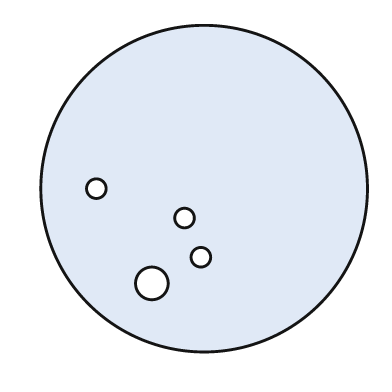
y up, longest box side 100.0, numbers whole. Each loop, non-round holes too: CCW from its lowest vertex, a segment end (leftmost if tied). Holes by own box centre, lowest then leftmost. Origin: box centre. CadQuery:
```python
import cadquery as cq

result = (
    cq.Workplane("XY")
    .moveTo(0.0, 0.0)
    .circle(50.0)
    .moveTo(-16.0, -29.0)
    .circle(5.0)
    .moveTo(-1.0, -21.0)
    .circle(3.0)
    .moveTo(-6.0, -9.0)
    .circle(3.0)
    .moveTo(-33.0, 0.0)
    .circle(3.0)
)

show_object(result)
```